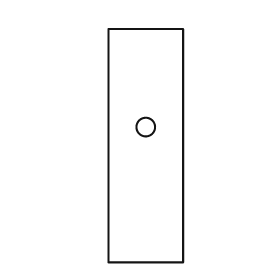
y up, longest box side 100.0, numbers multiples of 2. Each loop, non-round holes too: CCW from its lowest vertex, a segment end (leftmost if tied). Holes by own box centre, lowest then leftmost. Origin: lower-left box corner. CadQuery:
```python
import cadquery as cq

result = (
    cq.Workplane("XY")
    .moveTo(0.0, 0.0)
    .lineTo(32.0, 0.0)
    .lineTo(32.0, 100.0)
    .lineTo(0.0, 100.0)
    .close()
    .moveTo(16.0, 58.0)
    .circle(4.0)
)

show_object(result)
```